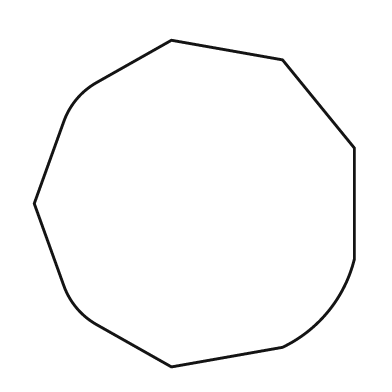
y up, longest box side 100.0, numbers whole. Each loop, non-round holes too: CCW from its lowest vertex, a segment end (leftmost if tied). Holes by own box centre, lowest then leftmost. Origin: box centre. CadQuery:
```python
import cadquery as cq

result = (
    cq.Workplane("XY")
    .moveTo(-7.0, -50.0)
    .lineTo(27.0, -44.0)
    .threePointArc((41.0, -33.0), (49.0, -17.0))
    .lineTo(49.0, 17.0)
    .lineTo(27.0, 44.0)
    .lineTo(-7.0, 50.0)
    .lineTo(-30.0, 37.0)
    .threePointArc((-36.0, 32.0), (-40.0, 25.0))
    .lineTo(-49.0, 0.0)
    .lineTo(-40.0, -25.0)
    .threePointArc((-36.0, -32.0), (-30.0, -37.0))
    .close()
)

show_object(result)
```